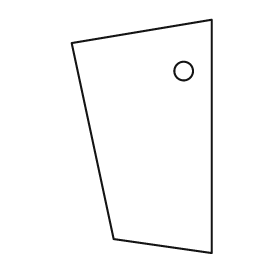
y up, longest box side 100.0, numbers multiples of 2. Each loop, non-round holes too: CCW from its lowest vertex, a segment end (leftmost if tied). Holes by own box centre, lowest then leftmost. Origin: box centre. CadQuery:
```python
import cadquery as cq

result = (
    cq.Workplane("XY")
    .moveTo(30.0, -50.0)
    .lineTo(30.0, 50.0)
    .lineTo(-30.0, 40.0)
    .lineTo(-12.0, -44.0)
    .close()
    .moveTo(18.0, 28.0)
    .circle(4.0)
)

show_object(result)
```